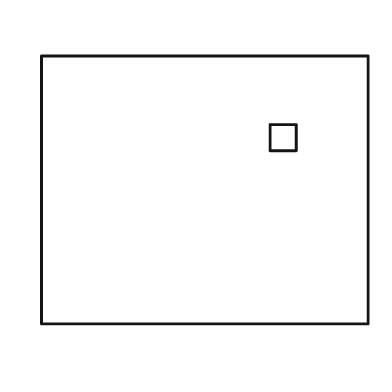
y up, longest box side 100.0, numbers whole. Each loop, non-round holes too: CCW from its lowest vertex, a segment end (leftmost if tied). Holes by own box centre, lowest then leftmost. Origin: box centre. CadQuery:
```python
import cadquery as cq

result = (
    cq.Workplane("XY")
    .moveTo(-50.0, -41.0)
    .lineTo(50.0, -41.0)
    .lineTo(50.0, 41.0)
    .lineTo(-50.0, 41.0)
    .close()
    .moveTo(20.0, 12.0)
    .lineTo(28.0, 12.0)
    .lineTo(28.0, 20.0)
    .lineTo(20.0, 20.0)
    .close()
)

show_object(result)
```